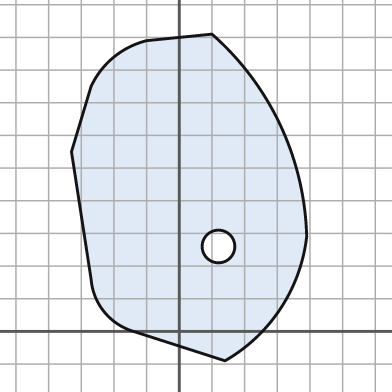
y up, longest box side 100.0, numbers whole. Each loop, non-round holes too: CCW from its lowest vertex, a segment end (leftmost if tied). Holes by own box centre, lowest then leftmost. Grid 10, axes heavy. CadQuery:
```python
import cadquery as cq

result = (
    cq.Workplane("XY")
    .moveTo(14.0, -9.0)
    .threePointArc((31.0, 7.0), (39.0, 29.0))
    .threePointArc((31.0, 63.0), (10.0, 91.0))
    .lineTo(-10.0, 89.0)
    .threePointArc((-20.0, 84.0), (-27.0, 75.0))
    .lineTo(-33.0, 55.0)
    .lineTo(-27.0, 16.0)
    .threePointArc((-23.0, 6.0), (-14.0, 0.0))
    .close()
    .moveTo(12.0, 26.0)
    .circle(5.0)
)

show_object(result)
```